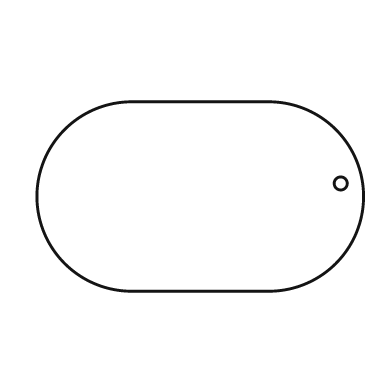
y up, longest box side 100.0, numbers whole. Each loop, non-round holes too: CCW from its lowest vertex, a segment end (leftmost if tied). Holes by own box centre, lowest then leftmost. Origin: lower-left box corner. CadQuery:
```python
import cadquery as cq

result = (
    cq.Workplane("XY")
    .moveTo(29.0, 0.0)
    .lineTo(71.0, 0.0)
    .threePointArc((100.0, 29.0), (71.0, 58.0))
    .lineTo(29.0, 58.0)
    .threePointArc((0.0, 29.0), (29.0, 0.0))
    .close()
    .moveTo(93.0, 33.0)
    .circle(2.0)
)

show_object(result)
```